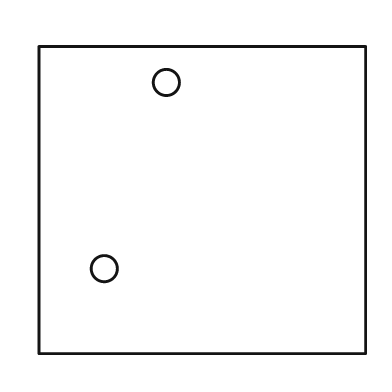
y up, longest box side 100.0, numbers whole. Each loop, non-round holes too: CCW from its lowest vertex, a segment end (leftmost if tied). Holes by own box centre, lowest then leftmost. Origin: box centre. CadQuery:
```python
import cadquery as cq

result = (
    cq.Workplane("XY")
    .moveTo(-50.0, -47.0)
    .lineTo(50.0, -47.0)
    .lineTo(50.0, 47.0)
    .lineTo(-50.0, 47.0)
    .close()
    .moveTo(-30.0, -21.0)
    .circle(4.0)
    .moveTo(-11.0, 36.0)
    .circle(4.0)
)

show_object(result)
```